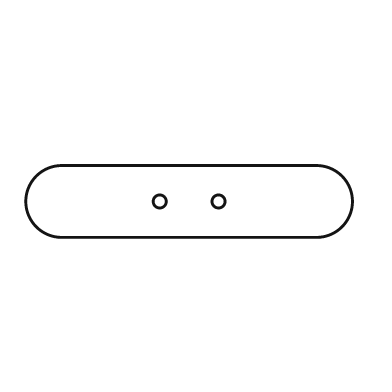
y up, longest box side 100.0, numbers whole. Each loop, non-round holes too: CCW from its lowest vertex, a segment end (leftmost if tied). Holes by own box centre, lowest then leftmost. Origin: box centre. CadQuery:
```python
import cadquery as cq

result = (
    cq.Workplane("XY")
    .moveTo(-39.0, -11.0)
    .lineTo(39.0, -11.0)
    .threePointArc((50.0, 0.0), (39.0, 11.0))
    .lineTo(-39.0, 11.0)
    .threePointArc((-50.0, 0.0), (-39.0, -11.0))
    .close()
    .moveTo(-9.0, 0.0)
    .circle(2.0)
    .moveTo(9.0, 0.0)
    .circle(2.0)
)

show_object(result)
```